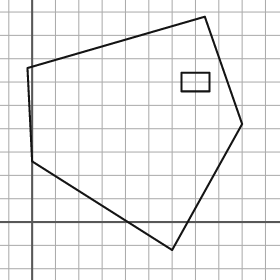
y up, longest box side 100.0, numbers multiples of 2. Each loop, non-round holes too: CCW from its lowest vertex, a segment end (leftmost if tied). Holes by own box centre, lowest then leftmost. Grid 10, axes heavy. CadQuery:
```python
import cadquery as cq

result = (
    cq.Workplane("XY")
    .moveTo(60.0, -12.0)
    .lineTo(90.0, 42.0)
    .lineTo(74.0, 88.0)
    .lineTo(-2.0, 66.0)
    .lineTo(0.0, 26.0)
    .close()
    .moveTo(64.0, 56.0)
    .lineTo(76.0, 56.0)
    .lineTo(76.0, 64.0)
    .lineTo(64.0, 64.0)
    .close()
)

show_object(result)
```